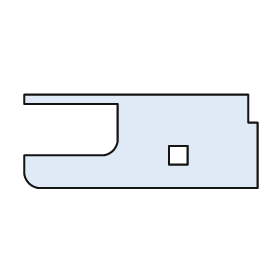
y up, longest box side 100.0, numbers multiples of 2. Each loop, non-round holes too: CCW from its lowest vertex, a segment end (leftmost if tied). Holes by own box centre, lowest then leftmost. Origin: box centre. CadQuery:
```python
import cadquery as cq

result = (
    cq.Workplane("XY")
    .moveTo(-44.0, -20.0)
    .lineTo(50.0, -20.0)
    .lineTo(50.0, 8.0)
    .lineTo(46.0, 8.0)
    .lineTo(46.0, 20.0)
    .lineTo(-50.0, 20.0)
    .lineTo(-50.0, 16.0)
    .lineTo(-10.0, 16.0)
    .lineTo(-10.0, 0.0)
    .threePointArc((-12.0, -4.0), (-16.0, -6.0))
    .lineTo(-50.0, -6.0)
    .lineTo(-50.0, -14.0)
    .threePointArc((-48.0, -18.0), (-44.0, -20.0))
    .close()
    .moveTo(12.0, -10.0)
    .lineTo(20.0, -10.0)
    .lineTo(20.0, -2.0)
    .lineTo(12.0, -2.0)
    .close()
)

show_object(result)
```